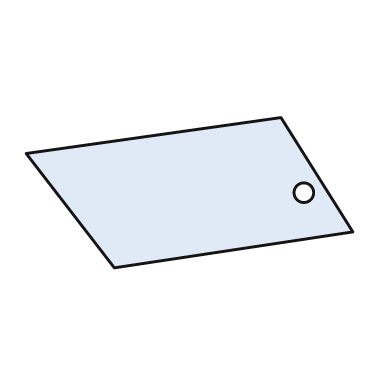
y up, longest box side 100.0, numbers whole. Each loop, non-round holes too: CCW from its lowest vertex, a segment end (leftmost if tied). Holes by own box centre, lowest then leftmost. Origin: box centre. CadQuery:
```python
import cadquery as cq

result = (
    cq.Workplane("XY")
    .moveTo(-23.0, -23.0)
    .lineTo(50.0, -12.0)
    .lineTo(28.0, 23.0)
    .lineTo(-50.0, 12.0)
    .close()
    .moveTo(35.0, 0.0)
    .circle(3.0)
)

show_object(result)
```